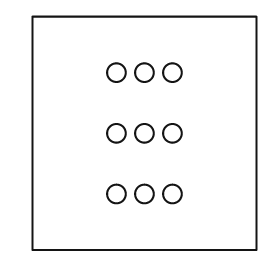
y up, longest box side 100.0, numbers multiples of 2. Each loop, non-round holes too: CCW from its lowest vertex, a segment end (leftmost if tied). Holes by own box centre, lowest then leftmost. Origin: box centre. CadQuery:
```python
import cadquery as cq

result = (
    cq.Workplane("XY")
    .moveTo(-48.0, -50.0)
    .lineTo(48.0, -50.0)
    .lineTo(48.0, 50.0)
    .lineTo(-48.0, 50.0)
    .close()
    .moveTo(-12.0, -26.0)
    .circle(4.0)
    .moveTo(0.0, -26.0)
    .circle(4.0)
    .moveTo(12.0, -26.0)
    .circle(4.0)
    .moveTo(-12.0, 0.0)
    .circle(4.0)
    .moveTo(0.0, 0.0)
    .circle(4.0)
    .moveTo(12.0, 0.0)
    .circle(4.0)
    .moveTo(-12.0, 26.0)
    .circle(4.0)
    .moveTo(0.0, 26.0)
    .circle(4.0)
    .moveTo(12.0, 26.0)
    .circle(4.0)
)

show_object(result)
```